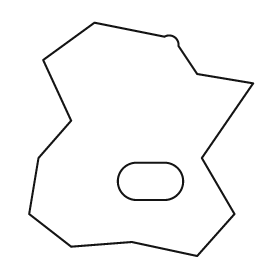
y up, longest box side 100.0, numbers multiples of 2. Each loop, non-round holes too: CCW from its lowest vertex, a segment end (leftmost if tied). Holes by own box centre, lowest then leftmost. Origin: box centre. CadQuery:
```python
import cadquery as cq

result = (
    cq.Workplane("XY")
    .moveTo(24.0, -50.0)
    .lineTo(40.0, -32.0)
    .lineTo(26.0, -8.0)
    .lineTo(48.0, 24.0)
    .lineTo(24.0, 28.0)
    .lineTo(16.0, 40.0)
    .threePointArc((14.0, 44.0), (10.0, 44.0))
    .lineTo(-20.0, 50.0)
    .lineTo(-42.0, 34.0)
    .lineTo(-30.0, 8.0)
    .lineTo(-44.0, -8.0)
    .lineTo(-48.0, -32.0)
    .lineTo(-30.0, -46.0)
    .lineTo(-4.0, -44.0)
    .close()
    .moveTo(-2.0, -26.0)
    .lineTo(10.0, -26.0)
    .threePointArc((18.0, -18.0), (10.0, -10.0))
    .lineTo(-2.0, -10.0)
    .threePointArc((-10.0, -18.0), (-2.0, -26.0))
    .close()
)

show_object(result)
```